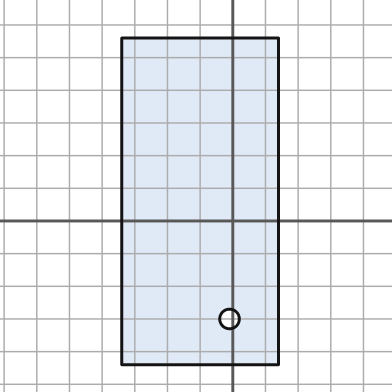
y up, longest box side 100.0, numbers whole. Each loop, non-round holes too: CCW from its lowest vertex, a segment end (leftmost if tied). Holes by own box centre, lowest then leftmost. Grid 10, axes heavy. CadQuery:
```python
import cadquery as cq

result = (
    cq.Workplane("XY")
    .moveTo(-34.0, -44.0)
    .lineTo(14.0, -44.0)
    .lineTo(14.0, 56.0)
    .lineTo(-34.0, 56.0)
    .close()
    .moveTo(-1.0, -30.0)
    .circle(3.0)
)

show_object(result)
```